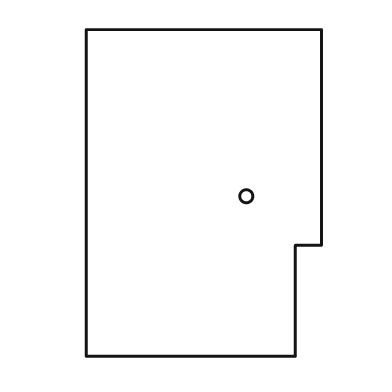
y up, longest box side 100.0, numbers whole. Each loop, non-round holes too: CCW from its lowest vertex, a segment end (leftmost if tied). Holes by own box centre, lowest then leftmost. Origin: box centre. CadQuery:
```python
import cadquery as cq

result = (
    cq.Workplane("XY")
    .moveTo(-36.0, -50.0)
    .lineTo(28.0, -50.0)
    .lineTo(28.0, -16.0)
    .lineTo(36.0, -16.0)
    .lineTo(36.0, 50.0)
    .lineTo(-36.0, 50.0)
    .close()
    .moveTo(13.0, -1.0)
    .circle(2.0)
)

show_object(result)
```